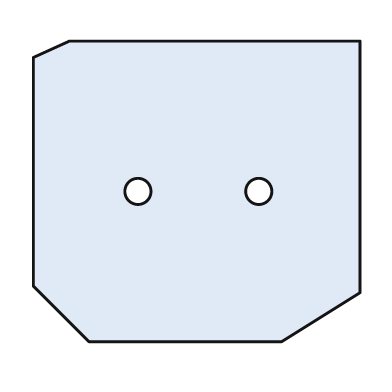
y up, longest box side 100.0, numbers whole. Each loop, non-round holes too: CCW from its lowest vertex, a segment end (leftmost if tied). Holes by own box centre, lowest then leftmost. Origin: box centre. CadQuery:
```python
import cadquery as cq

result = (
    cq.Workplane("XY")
    .moveTo(-33.0, -46.0)
    .lineTo(26.0, -46.0)
    .lineTo(50.0, -31.0)
    .lineTo(50.0, 46.0)
    .lineTo(-39.0, 46.0)
    .lineTo(-50.0, 41.0)
    .lineTo(-50.0, -29.0)
    .close()
    .moveTo(-18.0, 0.0)
    .circle(4.0)
    .moveTo(19.0, 0.0)
    .circle(4.0)
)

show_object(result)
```